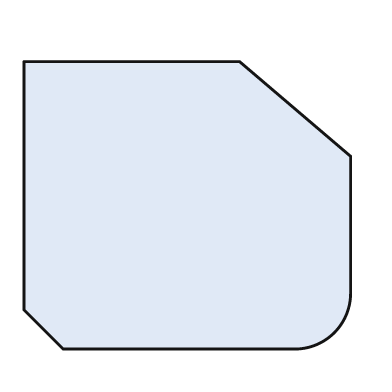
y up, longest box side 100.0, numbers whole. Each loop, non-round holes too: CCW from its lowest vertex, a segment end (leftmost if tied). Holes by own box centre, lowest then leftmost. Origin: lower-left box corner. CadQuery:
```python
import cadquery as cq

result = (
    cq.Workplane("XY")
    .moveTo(12.0, 0.0)
    .lineTo(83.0, 0.0)
    .threePointArc((95.0, 5.0), (100.0, 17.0))
    .lineTo(100.0, 59.0)
    .lineTo(66.0, 88.0)
    .lineTo(0.0, 88.0)
    .lineTo(0.0, 12.0)
    .close()
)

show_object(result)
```